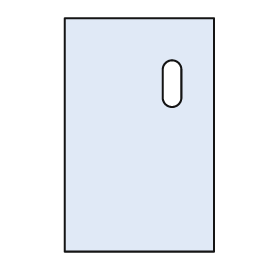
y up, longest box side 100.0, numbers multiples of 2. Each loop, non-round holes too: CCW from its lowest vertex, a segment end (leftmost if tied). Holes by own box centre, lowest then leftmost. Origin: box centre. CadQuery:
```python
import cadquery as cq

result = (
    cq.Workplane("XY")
    .moveTo(-32.0, -50.0)
    .lineTo(32.0, -50.0)
    .lineTo(32.0, 50.0)
    .lineTo(-32.0, 50.0)
    .close()
    .moveTo(10.0, 16.0)
    .threePointArc((14.0, 12.0), (18.0, 16.0))
    .lineTo(18.0, 28.0)
    .threePointArc((14.0, 32.0), (10.0, 28.0))
    .close()
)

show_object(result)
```